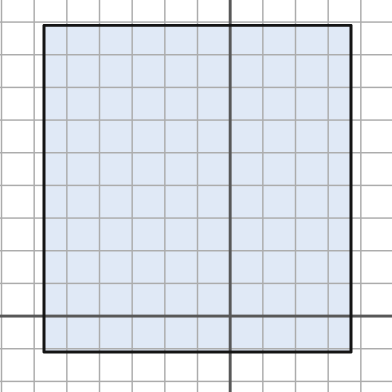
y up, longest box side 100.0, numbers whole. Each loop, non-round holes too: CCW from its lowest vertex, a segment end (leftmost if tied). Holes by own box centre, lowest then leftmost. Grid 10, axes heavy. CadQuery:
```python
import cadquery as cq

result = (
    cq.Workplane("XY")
    .moveTo(-57.0, -11.0)
    .lineTo(37.0, -11.0)
    .lineTo(37.0, 89.0)
    .lineTo(-57.0, 89.0)
    .close()
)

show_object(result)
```